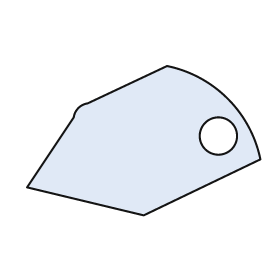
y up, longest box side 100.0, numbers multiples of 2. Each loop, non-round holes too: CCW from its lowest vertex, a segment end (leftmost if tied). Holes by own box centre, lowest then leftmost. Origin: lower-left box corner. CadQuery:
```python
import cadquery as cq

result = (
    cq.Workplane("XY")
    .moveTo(50.0, 0.0)
    .lineTo(100.0, 24.0)
    .threePointArc((86.0, 50.0), (60.0, 64.0))
    .lineTo(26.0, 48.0)
    .threePointArc((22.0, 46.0), (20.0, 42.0))
    .lineTo(0.0, 12.0)
    .close()
    .moveTo(82.0, 34.0)
    .circle(8.0)
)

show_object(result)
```